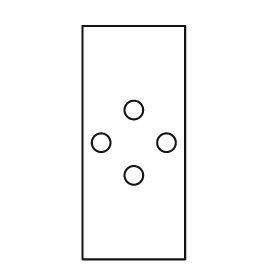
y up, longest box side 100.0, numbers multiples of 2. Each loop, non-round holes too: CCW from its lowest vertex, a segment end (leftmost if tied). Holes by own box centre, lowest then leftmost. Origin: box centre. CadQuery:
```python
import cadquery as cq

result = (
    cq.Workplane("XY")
    .moveTo(-22.0, -50.0)
    .lineTo(22.0, -50.0)
    .lineTo(22.0, 50.0)
    .lineTo(-22.0, 50.0)
    .close()
    .moveTo(0.0, -14.0)
    .circle(4.0)
    .moveTo(-14.0, 0.0)
    .circle(4.0)
    .moveTo(14.0, 0.0)
    .circle(4.0)
    .moveTo(0.0, 14.0)
    .circle(4.0)
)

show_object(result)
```